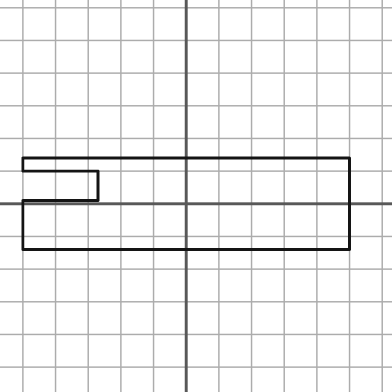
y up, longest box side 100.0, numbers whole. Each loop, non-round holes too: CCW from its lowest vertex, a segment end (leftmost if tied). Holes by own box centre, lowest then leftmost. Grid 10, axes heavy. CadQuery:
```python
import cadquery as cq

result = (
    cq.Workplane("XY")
    .moveTo(-50.0, -14.0)
    .lineTo(50.0, -14.0)
    .lineTo(50.0, 14.0)
    .lineTo(-50.0, 14.0)
    .lineTo(-50.0, 10.0)
    .lineTo(-27.0, 10.0)
    .lineTo(-27.0, 1.0)
    .lineTo(-50.0, 1.0)
    .close()
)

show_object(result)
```